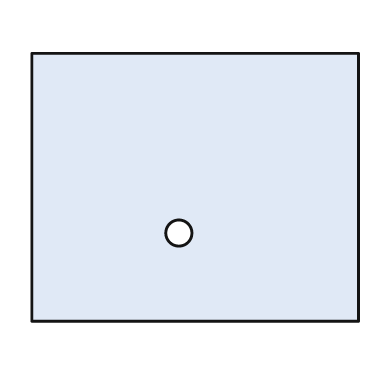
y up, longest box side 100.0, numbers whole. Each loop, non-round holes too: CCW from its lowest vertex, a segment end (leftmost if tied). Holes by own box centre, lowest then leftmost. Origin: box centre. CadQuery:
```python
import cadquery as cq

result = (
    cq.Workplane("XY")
    .moveTo(-50.0, -41.0)
    .lineTo(50.0, -41.0)
    .lineTo(50.0, 41.0)
    .lineTo(-50.0, 41.0)
    .close()
    .moveTo(-5.0, -14.0)
    .circle(4.0)
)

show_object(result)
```